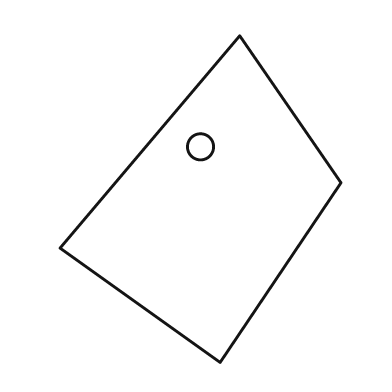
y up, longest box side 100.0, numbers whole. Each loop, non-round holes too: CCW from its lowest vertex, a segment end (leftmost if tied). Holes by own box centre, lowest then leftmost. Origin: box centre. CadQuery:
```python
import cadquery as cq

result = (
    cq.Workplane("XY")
    .moveTo(6.0, -50.0)
    .lineTo(43.0, 5.0)
    .lineTo(12.0, 50.0)
    .lineTo(-43.0, -15.0)
    .close()
    .moveTo(0.0, 16.0)
    .circle(4.0)
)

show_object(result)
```